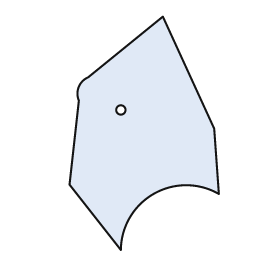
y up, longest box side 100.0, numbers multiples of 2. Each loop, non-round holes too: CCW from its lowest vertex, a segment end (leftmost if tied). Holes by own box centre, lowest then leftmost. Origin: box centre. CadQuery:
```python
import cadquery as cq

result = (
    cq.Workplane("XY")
    .moveTo(-10.0, -50.0)
    .threePointArc((4.0, -26.0), (32.0, -26.0))
    .lineTo(30.0, 2.0)
    .lineTo(8.0, 50.0)
    .lineTo(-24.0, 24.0)
    .threePointArc((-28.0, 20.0), (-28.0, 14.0))
    .lineTo(-32.0, -22.0)
    .close()
    .moveTo(-10.0, 10.0)
    .circle(2.0)
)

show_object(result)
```